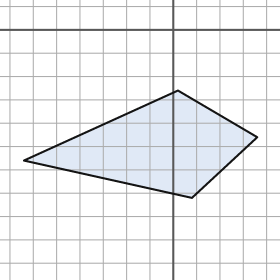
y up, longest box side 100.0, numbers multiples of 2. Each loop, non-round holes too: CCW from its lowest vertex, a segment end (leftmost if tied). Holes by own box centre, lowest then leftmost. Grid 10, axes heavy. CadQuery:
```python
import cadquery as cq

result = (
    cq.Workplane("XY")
    .moveTo(8.0, -72.0)
    .lineTo(36.0, -46.0)
    .lineTo(2.0, -26.0)
    .lineTo(-64.0, -56.0)
    .close()
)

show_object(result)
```